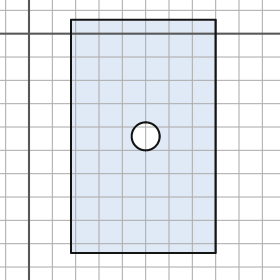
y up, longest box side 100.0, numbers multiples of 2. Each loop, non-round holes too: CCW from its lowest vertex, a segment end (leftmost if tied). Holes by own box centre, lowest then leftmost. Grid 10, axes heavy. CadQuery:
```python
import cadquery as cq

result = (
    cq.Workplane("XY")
    .moveTo(18.0, -94.0)
    .lineTo(80.0, -94.0)
    .lineTo(80.0, 6.0)
    .lineTo(18.0, 6.0)
    .close()
    .moveTo(50.0, -44.0)
    .circle(6.0)
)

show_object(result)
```